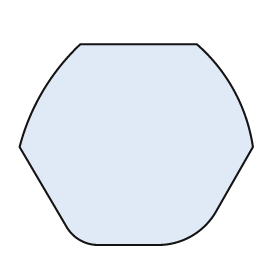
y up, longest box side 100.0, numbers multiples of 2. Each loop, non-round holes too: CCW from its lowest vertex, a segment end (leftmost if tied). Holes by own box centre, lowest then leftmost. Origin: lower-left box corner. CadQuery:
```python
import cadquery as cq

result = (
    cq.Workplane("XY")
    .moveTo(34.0, 0.0)
    .lineTo(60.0, 0.0)
    .threePointArc((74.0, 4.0), (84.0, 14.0))
    .lineTo(100.0, 42.0)
    .threePointArc((92.0, 66.0), (76.0, 86.0))
    .lineTo(26.0, 86.0)
    .threePointArc((10.0, 66.0), (0.0, 42.0))
    .lineTo(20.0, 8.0)
    .threePointArc((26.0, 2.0), (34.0, 0.0))
    .close()
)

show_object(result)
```